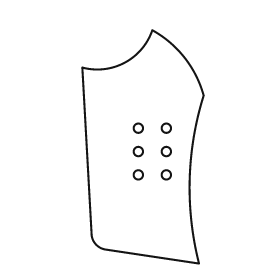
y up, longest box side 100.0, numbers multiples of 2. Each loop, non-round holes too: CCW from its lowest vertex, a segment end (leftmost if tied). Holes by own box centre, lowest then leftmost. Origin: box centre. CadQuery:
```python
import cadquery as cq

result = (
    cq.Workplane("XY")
    .moveTo(24.0, -50.0)
    .threePointArc((20.0, -14.0), (26.0, 22.0))
    .threePointArc((18.0, 38.0), (4.0, 50.0))
    .threePointArc((-8.0, 36.0), (-26.0, 34.0))
    .lineTo(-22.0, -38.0)
    .threePointArc((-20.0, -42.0), (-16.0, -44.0))
    .close()
    .moveTo(-2.0, -12.0)
    .circle(2.0)
    .moveTo(10.0, -12.0)
    .circle(2.0)
    .moveTo(-2.0, -2.0)
    .circle(2.0)
    .moveTo(10.0, -2.0)
    .circle(2.0)
    .moveTo(-2.0, 8.0)
    .circle(2.0)
    .moveTo(10.0, 8.0)
    .circle(2.0)
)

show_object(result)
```